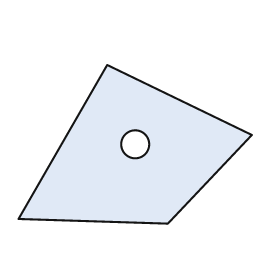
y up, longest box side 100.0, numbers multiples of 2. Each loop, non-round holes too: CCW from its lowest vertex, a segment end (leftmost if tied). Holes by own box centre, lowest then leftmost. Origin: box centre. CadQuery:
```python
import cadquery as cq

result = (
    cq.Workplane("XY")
    .moveTo(14.0, -34.0)
    .lineTo(50.0, 4.0)
    .lineTo(-12.0, 34.0)
    .lineTo(-50.0, -32.0)
    .close()
    .moveTo(0.0, 0.0)
    .circle(6.0)
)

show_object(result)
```